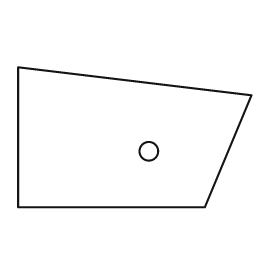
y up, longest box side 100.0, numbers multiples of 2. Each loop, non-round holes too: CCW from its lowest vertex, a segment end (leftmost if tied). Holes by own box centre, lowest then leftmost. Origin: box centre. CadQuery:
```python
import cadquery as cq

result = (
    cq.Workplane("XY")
    .moveTo(-50.0, -30.0)
    .lineTo(30.0, -30.0)
    .lineTo(50.0, 18.0)
    .lineTo(-50.0, 30.0)
    .close()
    .moveTo(6.0, -6.0)
    .circle(4.0)
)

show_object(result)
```